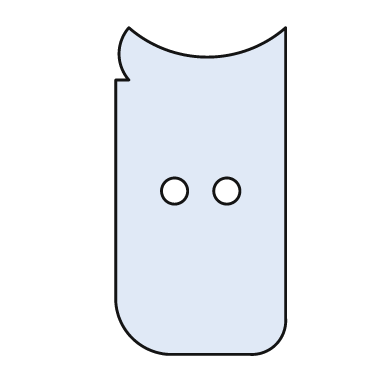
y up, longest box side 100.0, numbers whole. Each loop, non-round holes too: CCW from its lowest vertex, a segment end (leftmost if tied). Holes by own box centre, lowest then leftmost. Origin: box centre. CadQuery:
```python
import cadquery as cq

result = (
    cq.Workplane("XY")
    .moveTo(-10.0, -50.0)
    .lineTo(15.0, -50.0)
    .threePointArc((23.0, -47.0), (26.0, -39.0))
    .lineTo(26.0, 50.0)
    .threePointArc((2.0, 41.0), (-22.0, 50.0))
    .threePointArc((-25.0, 42.0), (-22.0, 34.0))
    .lineTo(-26.0, 34.0)
    .lineTo(-26.0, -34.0)
    .threePointArc((-21.0, -45.0), (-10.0, -50.0))
    .close()
    .moveTo(-8.0, 0.0)
    .circle(4.0)
    .moveTo(8.0, 0.0)
    .circle(4.0)
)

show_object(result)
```